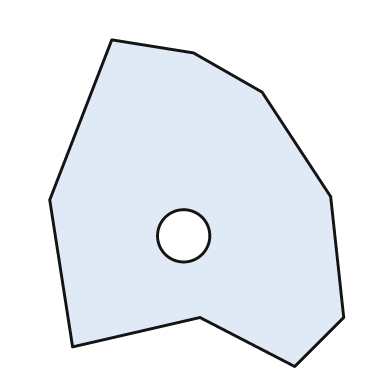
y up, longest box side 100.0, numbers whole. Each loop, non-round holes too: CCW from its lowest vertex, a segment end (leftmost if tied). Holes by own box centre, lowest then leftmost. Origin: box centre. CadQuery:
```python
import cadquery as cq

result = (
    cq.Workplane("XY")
    .moveTo(30.0, -50.0)
    .lineTo(45.0, -35.0)
    .lineTo(41.0, 2.0)
    .lineTo(20.0, 34.0)
    .lineTo(-1.0, 46.0)
    .lineTo(-26.0, 50.0)
    .lineTo(-45.0, 1.0)
    .lineTo(-38.0, -44.0)
    .lineTo(1.0, -35.0)
    .close()
    .moveTo(-4.0, -10.0)
    .circle(8.0)
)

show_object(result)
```